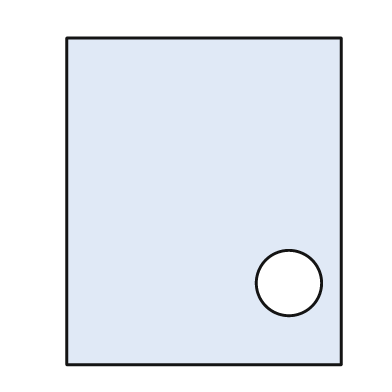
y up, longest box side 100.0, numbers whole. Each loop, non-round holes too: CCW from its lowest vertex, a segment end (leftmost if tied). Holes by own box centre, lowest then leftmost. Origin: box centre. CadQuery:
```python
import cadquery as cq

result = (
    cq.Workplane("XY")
    .moveTo(-42.0, -50.0)
    .lineTo(42.0, -50.0)
    .lineTo(42.0, 50.0)
    .lineTo(-42.0, 50.0)
    .close()
    .moveTo(26.0, -25.0)
    .circle(10.0)
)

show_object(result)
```